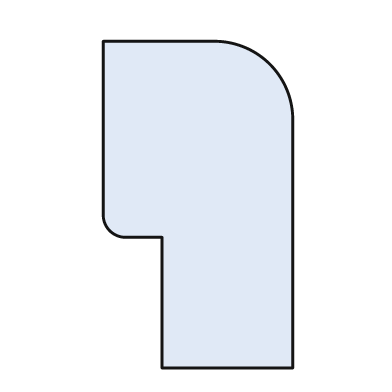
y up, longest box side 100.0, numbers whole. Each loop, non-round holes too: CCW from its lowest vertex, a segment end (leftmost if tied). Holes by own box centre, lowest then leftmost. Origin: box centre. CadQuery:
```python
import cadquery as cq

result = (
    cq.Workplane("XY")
    .moveTo(-11.0, -50.0)
    .lineTo(29.0, -50.0)
    .lineTo(29.0, 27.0)
    .threePointArc((22.0, 43.0), (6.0, 50.0))
    .lineTo(-29.0, 50.0)
    .lineTo(-29.0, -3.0)
    .threePointArc((-27.0, -8.0), (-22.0, -10.0))
    .lineTo(-11.0, -10.0)
    .close()
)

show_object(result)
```